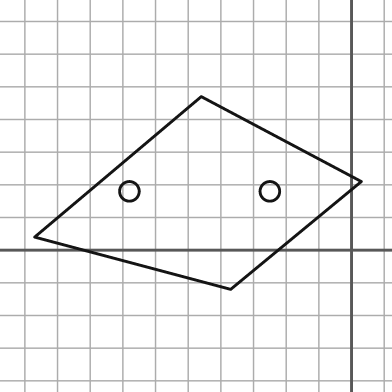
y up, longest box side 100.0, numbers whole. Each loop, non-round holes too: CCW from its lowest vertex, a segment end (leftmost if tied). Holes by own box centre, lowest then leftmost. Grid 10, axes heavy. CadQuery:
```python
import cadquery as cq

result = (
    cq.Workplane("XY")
    .moveTo(-37.0, -12.0)
    .lineTo(3.0, 21.0)
    .lineTo(-46.0, 47.0)
    .lineTo(-97.0, 4.0)
    .close()
    .moveTo(-68.0, 18.0)
    .circle(3.0)
    .moveTo(-25.0, 18.0)
    .circle(3.0)
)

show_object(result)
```